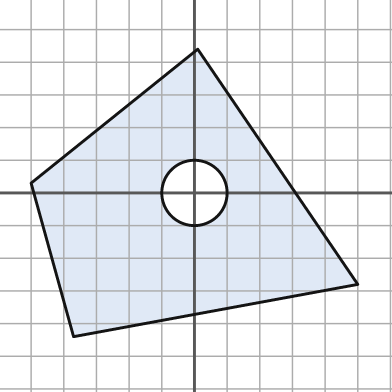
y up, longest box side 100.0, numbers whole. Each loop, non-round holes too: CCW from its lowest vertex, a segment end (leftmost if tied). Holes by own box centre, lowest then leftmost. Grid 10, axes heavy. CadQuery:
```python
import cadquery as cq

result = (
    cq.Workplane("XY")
    .moveTo(-37.0, -44.0)
    .lineTo(50.0, -28.0)
    .lineTo(1.0, 44.0)
    .lineTo(-50.0, 3.0)
    .close()
    .moveTo(0.0, 0.0)
    .circle(10.0)
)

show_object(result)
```